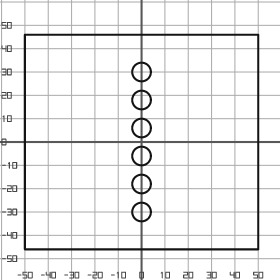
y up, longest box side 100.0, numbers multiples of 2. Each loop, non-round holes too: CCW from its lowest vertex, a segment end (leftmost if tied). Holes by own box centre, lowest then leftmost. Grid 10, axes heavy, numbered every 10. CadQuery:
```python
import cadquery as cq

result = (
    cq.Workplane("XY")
    .moveTo(-50.0, -46.0)
    .lineTo(50.0, -46.0)
    .lineTo(50.0, 46.0)
    .lineTo(-50.0, 46.0)
    .close()
    .moveTo(0.0, -30.0)
    .circle(4.0)
    .moveTo(0.0, -18.0)
    .circle(4.0)
    .moveTo(0.0, -6.0)
    .circle(4.0)
    .moveTo(0.0, 6.0)
    .circle(4.0)
    .moveTo(0.0, 18.0)
    .circle(4.0)
    .moveTo(0.0, 30.0)
    .circle(4.0)
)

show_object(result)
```